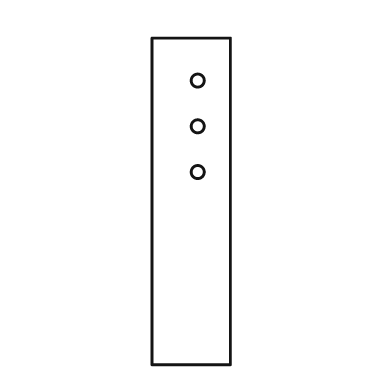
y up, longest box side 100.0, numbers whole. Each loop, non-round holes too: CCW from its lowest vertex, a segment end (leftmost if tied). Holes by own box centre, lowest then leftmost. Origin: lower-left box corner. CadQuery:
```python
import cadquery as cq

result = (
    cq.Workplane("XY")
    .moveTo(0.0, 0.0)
    .lineTo(24.0, 0.0)
    .lineTo(24.0, 100.0)
    .lineTo(0.0, 100.0)
    .close()
    .moveTo(14.0, 59.0)
    .circle(2.0)
    .moveTo(14.0, 73.0)
    .circle(2.0)
    .moveTo(14.0, 87.0)
    .circle(2.0)
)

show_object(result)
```